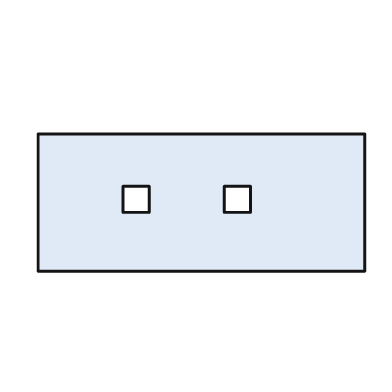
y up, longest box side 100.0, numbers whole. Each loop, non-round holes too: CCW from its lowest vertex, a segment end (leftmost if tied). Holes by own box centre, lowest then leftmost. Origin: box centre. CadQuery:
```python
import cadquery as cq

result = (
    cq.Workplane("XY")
    .moveTo(-50.0, -21.0)
    .lineTo(50.0, -21.0)
    .lineTo(50.0, 21.0)
    .lineTo(-50.0, 21.0)
    .close()
    .moveTo(-24.0, -3.0)
    .lineTo(-16.0, -3.0)
    .lineTo(-16.0, 5.0)
    .lineTo(-24.0, 5.0)
    .close()
    .moveTo(7.0, -3.0)
    .lineTo(15.0, -3.0)
    .lineTo(15.0, 5.0)
    .lineTo(7.0, 5.0)
    .close()
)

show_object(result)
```